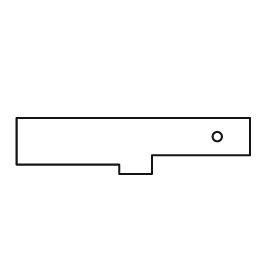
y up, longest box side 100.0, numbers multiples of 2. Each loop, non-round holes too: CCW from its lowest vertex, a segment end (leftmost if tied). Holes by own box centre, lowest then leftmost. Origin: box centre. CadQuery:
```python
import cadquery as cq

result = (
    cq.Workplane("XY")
    .moveTo(-6.0, -12.0)
    .lineTo(8.0, -12.0)
    .lineTo(8.0, -4.0)
    .lineTo(50.0, -4.0)
    .lineTo(50.0, 12.0)
    .lineTo(-50.0, 12.0)
    .lineTo(-50.0, -8.0)
    .lineTo(-6.0, -8.0)
    .close()
    .moveTo(36.0, 4.0)
    .circle(2.0)
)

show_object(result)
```